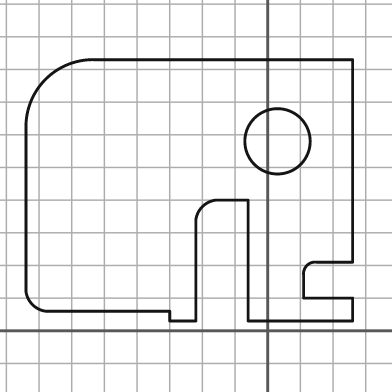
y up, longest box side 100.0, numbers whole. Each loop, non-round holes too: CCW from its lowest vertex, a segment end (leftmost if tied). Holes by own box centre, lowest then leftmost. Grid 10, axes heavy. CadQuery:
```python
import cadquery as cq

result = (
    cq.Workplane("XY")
    .moveTo(-30.0, 3.0)
    .lineTo(-22.0, 3.0)
    .lineTo(-22.0, 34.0)
    .threePointArc((-20.0, 38.0), (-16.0, 40.0))
    .lineTo(-6.0, 40.0)
    .lineTo(-6.0, 3.0)
    .lineTo(26.0, 3.0)
    .lineTo(26.0, 10.0)
    .lineTo(11.0, 10.0)
    .lineTo(11.0, 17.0)
    .threePointArc((12.0, 20.0), (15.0, 21.0))
    .lineTo(26.0, 21.0)
    .lineTo(26.0, 83.0)
    .lineTo(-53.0, 83.0)
    .threePointArc((-68.0, 77.0), (-74.0, 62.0))
    .lineTo(-74.0, 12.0)
    .threePointArc((-72.0, 8.0), (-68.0, 6.0))
    .lineTo(-30.0, 6.0)
    .close()
    .moveTo(3.0, 58.0)
    .circle(10.0)
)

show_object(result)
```